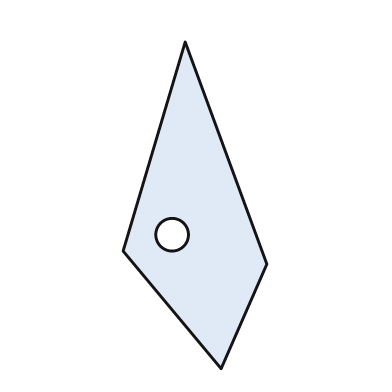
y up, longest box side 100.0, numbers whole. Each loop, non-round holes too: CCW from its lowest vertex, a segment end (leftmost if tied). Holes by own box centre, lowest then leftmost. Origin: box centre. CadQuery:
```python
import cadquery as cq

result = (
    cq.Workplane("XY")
    .moveTo(8.0, -50.0)
    .lineTo(22.0, -18.0)
    .lineTo(-3.0, 50.0)
    .lineTo(-22.0, -14.0)
    .close()
    .moveTo(-7.0, -9.0)
    .circle(5.0)
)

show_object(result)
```